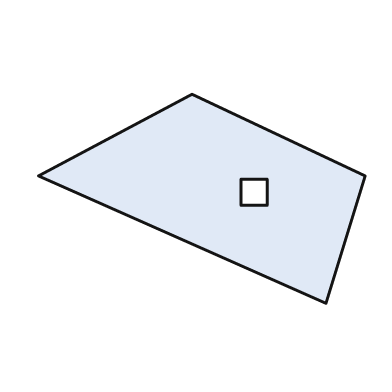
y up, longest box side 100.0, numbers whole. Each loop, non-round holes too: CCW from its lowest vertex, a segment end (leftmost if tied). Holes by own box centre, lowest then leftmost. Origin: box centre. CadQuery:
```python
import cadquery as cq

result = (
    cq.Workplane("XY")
    .moveTo(38.0, -32.0)
    .lineTo(50.0, 7.0)
    .lineTo(-3.0, 32.0)
    .lineTo(-50.0, 7.0)
    .close()
    .moveTo(12.0, -2.0)
    .lineTo(20.0, -2.0)
    .lineTo(20.0, 6.0)
    .lineTo(12.0, 6.0)
    .close()
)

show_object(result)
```